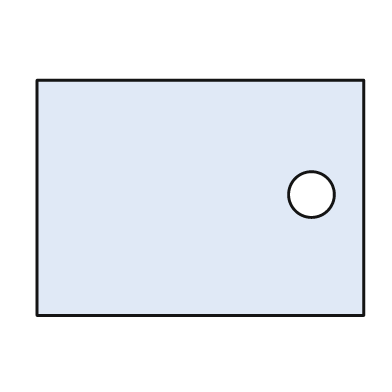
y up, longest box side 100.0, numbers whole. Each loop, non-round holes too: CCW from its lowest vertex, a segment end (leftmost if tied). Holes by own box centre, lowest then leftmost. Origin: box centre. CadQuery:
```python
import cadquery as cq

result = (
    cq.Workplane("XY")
    .moveTo(-50.0, -36.0)
    .lineTo(50.0, -36.0)
    .lineTo(50.0, 36.0)
    .lineTo(-50.0, 36.0)
    .close()
    .moveTo(34.0, 1.0)
    .circle(7.0)
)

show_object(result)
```